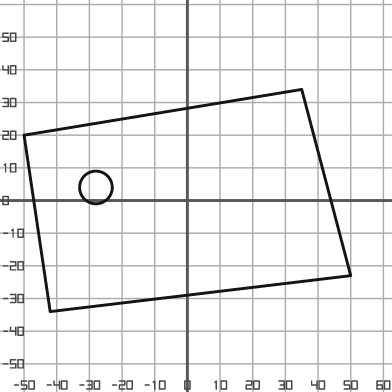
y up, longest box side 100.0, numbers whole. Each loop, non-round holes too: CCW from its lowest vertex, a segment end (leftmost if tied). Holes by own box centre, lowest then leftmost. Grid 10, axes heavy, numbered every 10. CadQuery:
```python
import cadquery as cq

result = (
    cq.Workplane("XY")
    .moveTo(-42.0, -34.0)
    .lineTo(50.0, -23.0)
    .lineTo(35.0, 34.0)
    .lineTo(-50.0, 20.0)
    .close()
    .moveTo(-28.0, 4.0)
    .circle(5.0)
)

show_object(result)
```